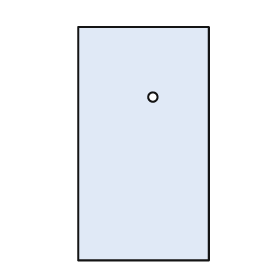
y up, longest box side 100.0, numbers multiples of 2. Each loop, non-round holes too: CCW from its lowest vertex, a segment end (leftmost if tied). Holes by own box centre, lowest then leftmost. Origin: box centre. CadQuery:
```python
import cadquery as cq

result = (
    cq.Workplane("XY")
    .moveTo(-28.0, -50.0)
    .lineTo(28.0, -50.0)
    .lineTo(28.0, 50.0)
    .lineTo(-28.0, 50.0)
    .close()
    .moveTo(4.0, 20.0)
    .circle(2.0)
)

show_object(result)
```